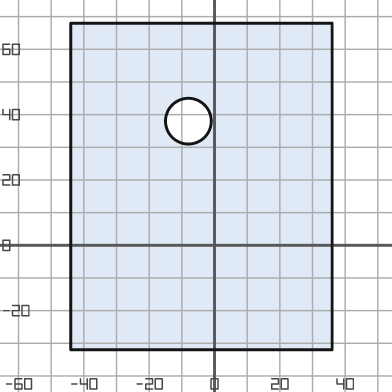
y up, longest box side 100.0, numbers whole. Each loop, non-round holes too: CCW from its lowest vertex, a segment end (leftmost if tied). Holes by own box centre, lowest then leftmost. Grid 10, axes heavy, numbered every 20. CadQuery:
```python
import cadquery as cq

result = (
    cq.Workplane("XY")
    .moveTo(-44.0, -32.0)
    .lineTo(36.0, -32.0)
    .lineTo(36.0, 68.0)
    .lineTo(-44.0, 68.0)
    .close()
    .moveTo(-8.0, 38.0)
    .circle(7.0)
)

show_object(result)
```